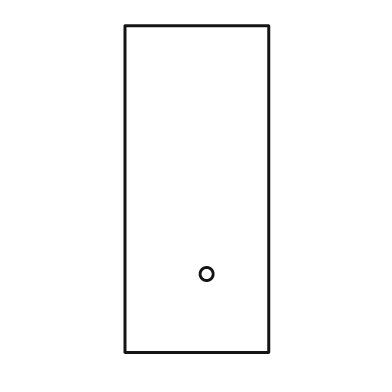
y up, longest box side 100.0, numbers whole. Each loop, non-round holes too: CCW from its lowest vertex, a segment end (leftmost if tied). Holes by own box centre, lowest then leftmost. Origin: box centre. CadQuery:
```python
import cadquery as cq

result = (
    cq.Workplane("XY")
    .moveTo(-22.0, -50.0)
    .lineTo(22.0, -50.0)
    .lineTo(22.0, 50.0)
    .lineTo(-22.0, 50.0)
    .close()
    .moveTo(3.0, -26.0)
    .circle(2.0)
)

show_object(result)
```